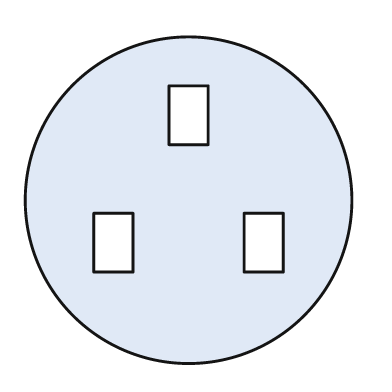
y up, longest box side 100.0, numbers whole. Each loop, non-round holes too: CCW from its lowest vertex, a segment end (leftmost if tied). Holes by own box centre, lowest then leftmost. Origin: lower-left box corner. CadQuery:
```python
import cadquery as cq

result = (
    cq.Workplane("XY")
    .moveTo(50.0, 50.0)
    .circle(50.0)
    .moveTo(21.0, 28.0)
    .lineTo(33.0, 28.0)
    .lineTo(33.0, 46.0)
    .lineTo(21.0, 46.0)
    .close()
    .moveTo(67.0, 28.0)
    .lineTo(79.0, 28.0)
    .lineTo(79.0, 46.0)
    .lineTo(67.0, 46.0)
    .close()
    .moveTo(44.0, 67.0)
    .lineTo(56.0, 67.0)
    .lineTo(56.0, 85.0)
    .lineTo(44.0, 85.0)
    .close()
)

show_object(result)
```